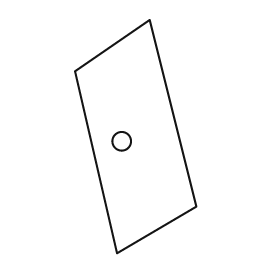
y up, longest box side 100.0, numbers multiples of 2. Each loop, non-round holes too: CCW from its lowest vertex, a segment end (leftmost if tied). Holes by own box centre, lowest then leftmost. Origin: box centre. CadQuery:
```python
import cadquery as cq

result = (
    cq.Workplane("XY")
    .moveTo(-8.0, -50.0)
    .lineTo(26.0, -30.0)
    .lineTo(6.0, 50.0)
    .lineTo(-26.0, 28.0)
    .close()
    .moveTo(-6.0, -2.0)
    .circle(4.0)
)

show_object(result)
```